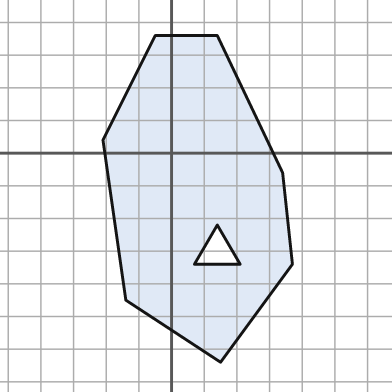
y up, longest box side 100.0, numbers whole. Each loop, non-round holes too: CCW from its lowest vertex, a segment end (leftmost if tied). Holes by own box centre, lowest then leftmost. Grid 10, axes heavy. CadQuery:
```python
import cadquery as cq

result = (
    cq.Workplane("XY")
    .moveTo(15.0, -64.0)
    .lineTo(37.0, -34.0)
    .lineTo(34.0, -6.0)
    .lineTo(14.0, 36.0)
    .lineTo(-5.0, 36.0)
    .lineTo(-21.0, 4.0)
    .lineTo(-14.0, -45.0)
    .close()
    .moveTo(7.0, -34.0)
    .lineTo(21.0, -34.0)
    .lineTo(14.0, -22.0)
    .close()
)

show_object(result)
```